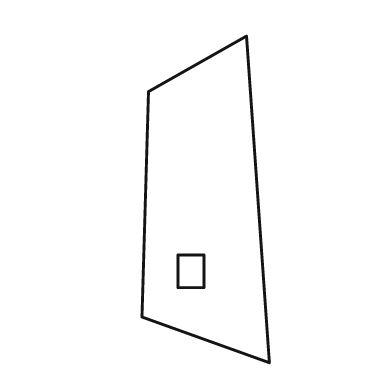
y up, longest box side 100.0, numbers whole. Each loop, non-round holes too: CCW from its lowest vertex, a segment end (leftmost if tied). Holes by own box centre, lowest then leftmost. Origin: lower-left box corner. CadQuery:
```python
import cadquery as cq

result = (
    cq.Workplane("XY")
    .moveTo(39.0, 0.0)
    .lineTo(32.0, 100.0)
    .lineTo(2.0, 83.0)
    .lineTo(0.0, 14.0)
    .close()
    .moveTo(11.0, 23.0)
    .lineTo(19.0, 23.0)
    .lineTo(19.0, 33.0)
    .lineTo(11.0, 33.0)
    .close()
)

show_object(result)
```